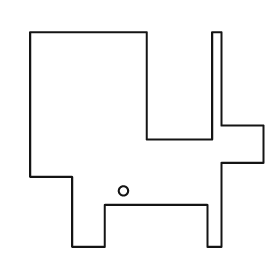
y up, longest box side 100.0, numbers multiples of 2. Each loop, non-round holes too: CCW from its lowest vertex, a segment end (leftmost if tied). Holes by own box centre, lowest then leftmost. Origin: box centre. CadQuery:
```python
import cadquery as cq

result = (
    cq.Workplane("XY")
    .moveTo(-32.0, -46.0)
    .lineTo(-18.0, -46.0)
    .lineTo(-18.0, -28.0)
    .lineTo(26.0, -28.0)
    .lineTo(26.0, -46.0)
    .lineTo(32.0, -46.0)
    .lineTo(32.0, -10.0)
    .lineTo(50.0, -10.0)
    .lineTo(50.0, 6.0)
    .lineTo(32.0, 6.0)
    .lineTo(32.0, 46.0)
    .lineTo(28.0, 46.0)
    .lineTo(28.0, 0.0)
    .lineTo(0.0, 0.0)
    .lineTo(0.0, 46.0)
    .lineTo(-50.0, 46.0)
    .lineTo(-50.0, -16.0)
    .lineTo(-32.0, -16.0)
    .close()
    .moveTo(-10.0, -22.0)
    .circle(2.0)
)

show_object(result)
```